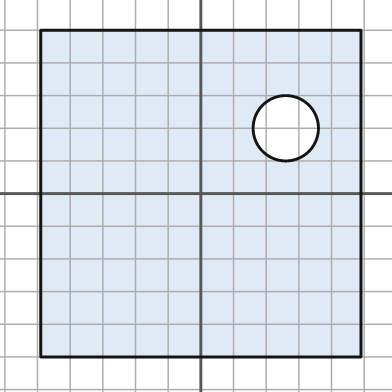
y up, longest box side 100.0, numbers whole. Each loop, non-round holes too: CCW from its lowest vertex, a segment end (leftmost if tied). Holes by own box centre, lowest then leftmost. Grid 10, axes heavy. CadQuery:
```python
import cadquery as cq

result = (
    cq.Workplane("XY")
    .moveTo(-49.0, -50.0)
    .lineTo(49.0, -50.0)
    .lineTo(49.0, 50.0)
    .lineTo(-49.0, 50.0)
    .close()
    .moveTo(26.0, 20.0)
    .circle(10.0)
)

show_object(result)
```